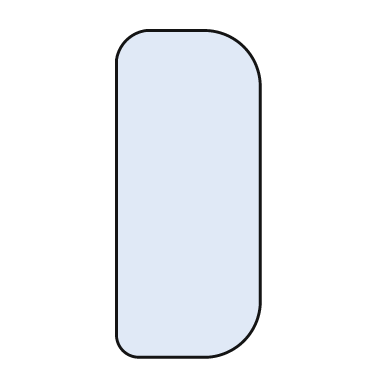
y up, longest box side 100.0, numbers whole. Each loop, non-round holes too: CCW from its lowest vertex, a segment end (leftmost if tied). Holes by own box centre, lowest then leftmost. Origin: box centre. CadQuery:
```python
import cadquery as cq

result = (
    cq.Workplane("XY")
    .moveTo(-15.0, -50.0)
    .lineTo(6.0, -50.0)
    .threePointArc((17.0, -45.0), (22.0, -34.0))
    .lineTo(22.0, 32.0)
    .threePointArc((17.0, 45.0), (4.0, 50.0))
    .lineTo(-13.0, 50.0)
    .threePointArc((-19.0, 47.0), (-22.0, 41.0))
    .lineTo(-22.0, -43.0)
    .threePointArc((-20.0, -48.0), (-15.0, -50.0))
    .close()
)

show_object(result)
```